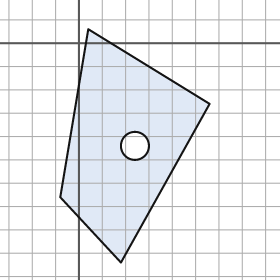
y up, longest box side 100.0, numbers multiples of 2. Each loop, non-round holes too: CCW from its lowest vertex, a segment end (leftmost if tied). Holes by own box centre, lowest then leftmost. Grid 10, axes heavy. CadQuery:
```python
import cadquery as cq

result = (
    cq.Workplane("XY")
    .moveTo(18.0, -94.0)
    .lineTo(56.0, -26.0)
    .lineTo(4.0, 6.0)
    .lineTo(-8.0, -66.0)
    .close()
    .moveTo(24.0, -44.0)
    .circle(6.0)
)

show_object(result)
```